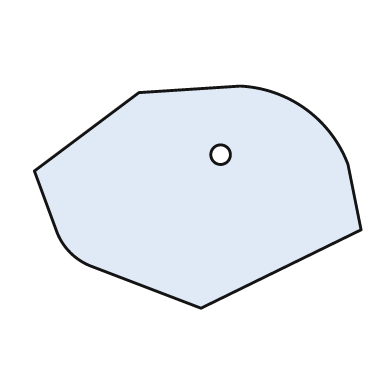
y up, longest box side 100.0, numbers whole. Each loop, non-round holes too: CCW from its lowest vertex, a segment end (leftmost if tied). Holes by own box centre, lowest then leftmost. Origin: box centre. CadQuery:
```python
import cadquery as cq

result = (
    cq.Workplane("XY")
    .moveTo(1.0, -34.0)
    .lineTo(50.0, -10.0)
    .lineTo(46.0, 10.0)
    .threePointArc((33.0, 27.0), (13.0, 34.0))
    .lineTo(-18.0, 32.0)
    .lineTo(-50.0, 8.0)
    .lineTo(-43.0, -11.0)
    .threePointArc((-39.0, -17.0), (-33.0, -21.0))
    .close()
    .moveTo(7.0, 13.0)
    .circle(3.0)
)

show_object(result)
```